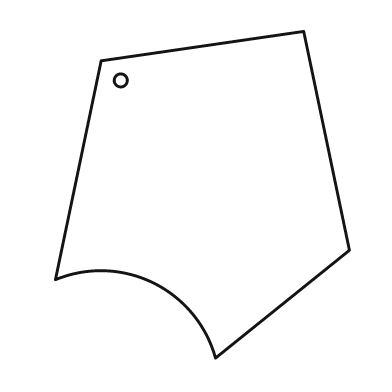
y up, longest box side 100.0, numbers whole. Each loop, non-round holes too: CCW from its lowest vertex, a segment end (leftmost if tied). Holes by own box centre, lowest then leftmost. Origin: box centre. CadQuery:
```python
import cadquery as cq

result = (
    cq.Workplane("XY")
    .moveTo(4.0, -50.0)
    .lineTo(45.0, -17.0)
    .lineTo(31.0, 50.0)
    .lineTo(-31.0, 41.0)
    .lineTo(-45.0, -26.0)
    .threePointArc((-15.0, -27.0), (4.0, -50.0))
    .close()
    .moveTo(-25.0, 35.0)
    .circle(2.0)
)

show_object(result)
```